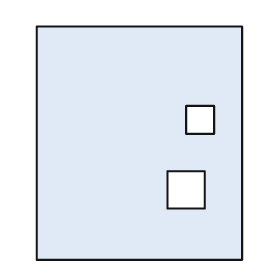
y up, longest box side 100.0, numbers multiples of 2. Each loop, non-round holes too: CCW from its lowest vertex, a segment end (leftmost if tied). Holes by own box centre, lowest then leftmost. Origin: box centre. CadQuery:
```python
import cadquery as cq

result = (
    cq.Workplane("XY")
    .moveTo(-44.0, -50.0)
    .lineTo(44.0, -50.0)
    .lineTo(44.0, 50.0)
    .lineTo(-44.0, 50.0)
    .close()
    .moveTo(12.0, -28.0)
    .lineTo(28.0, -28.0)
    .lineTo(28.0, -12.0)
    .lineTo(12.0, -12.0)
    .close()
    .moveTo(20.0, 4.0)
    .lineTo(32.0, 4.0)
    .lineTo(32.0, 16.0)
    .lineTo(20.0, 16.0)
    .close()
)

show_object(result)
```